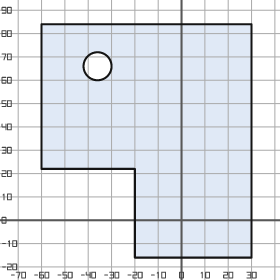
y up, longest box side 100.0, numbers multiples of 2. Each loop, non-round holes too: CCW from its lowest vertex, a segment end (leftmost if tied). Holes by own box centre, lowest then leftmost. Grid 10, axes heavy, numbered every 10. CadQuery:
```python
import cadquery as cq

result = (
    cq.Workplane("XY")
    .moveTo(-20.0, -16.0)
    .lineTo(30.0, -16.0)
    .lineTo(30.0, 84.0)
    .lineTo(-60.0, 84.0)
    .lineTo(-60.0, 22.0)
    .lineTo(-20.0, 22.0)
    .close()
    .moveTo(-36.0, 66.0)
    .circle(6.0)
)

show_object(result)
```